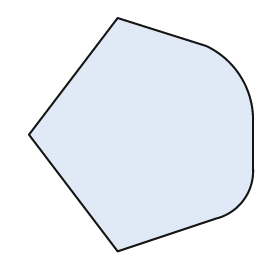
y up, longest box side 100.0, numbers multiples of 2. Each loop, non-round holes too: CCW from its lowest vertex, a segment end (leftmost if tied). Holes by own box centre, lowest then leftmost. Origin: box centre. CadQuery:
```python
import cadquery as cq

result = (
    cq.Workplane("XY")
    .moveTo(-10.0, -50.0)
    .lineTo(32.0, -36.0)
    .threePointArc((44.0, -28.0), (48.0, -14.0))
    .lineTo(48.0, 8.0)
    .threePointArc((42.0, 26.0), (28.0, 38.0))
    .lineTo(-10.0, 50.0)
    .lineTo(-48.0, 0.0)
    .close()
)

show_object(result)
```